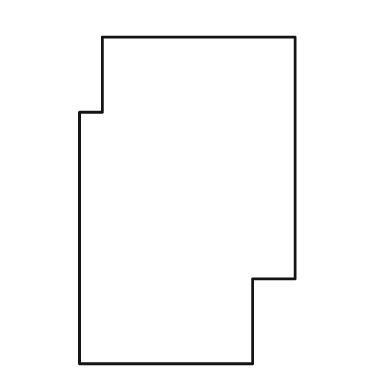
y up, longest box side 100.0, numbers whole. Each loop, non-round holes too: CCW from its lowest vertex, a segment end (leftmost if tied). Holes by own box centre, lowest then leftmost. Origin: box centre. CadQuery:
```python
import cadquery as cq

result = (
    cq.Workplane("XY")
    .moveTo(-33.0, -50.0)
    .lineTo(20.0, -50.0)
    .lineTo(20.0, -24.0)
    .lineTo(33.0, -24.0)
    .lineTo(33.0, 50.0)
    .lineTo(-26.0, 50.0)
    .lineTo(-26.0, 27.0)
    .lineTo(-33.0, 27.0)
    .close()
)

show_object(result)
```